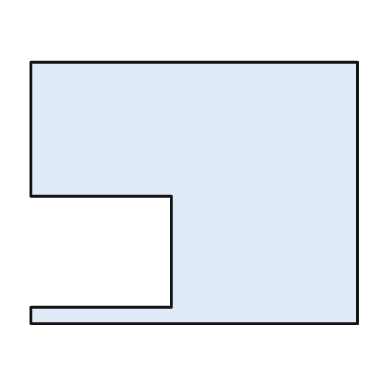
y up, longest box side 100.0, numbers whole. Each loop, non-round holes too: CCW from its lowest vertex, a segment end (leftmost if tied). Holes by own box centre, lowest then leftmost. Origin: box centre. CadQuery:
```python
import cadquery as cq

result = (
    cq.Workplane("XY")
    .moveTo(-50.0, -40.0)
    .lineTo(50.0, -40.0)
    .lineTo(50.0, 40.0)
    .lineTo(-50.0, 40.0)
    .lineTo(-50.0, -1.0)
    .lineTo(-7.0, -1.0)
    .lineTo(-7.0, -35.0)
    .lineTo(-50.0, -35.0)
    .close()
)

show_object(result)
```